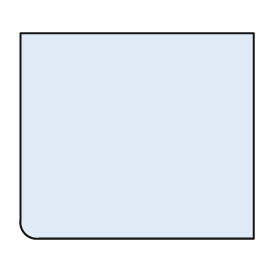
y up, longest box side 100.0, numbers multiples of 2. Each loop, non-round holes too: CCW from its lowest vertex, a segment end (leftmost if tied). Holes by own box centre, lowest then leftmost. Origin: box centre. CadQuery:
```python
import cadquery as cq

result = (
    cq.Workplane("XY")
    .moveTo(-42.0, -44.0)
    .lineTo(50.0, -44.0)
    .lineTo(50.0, 44.0)
    .lineTo(-50.0, 44.0)
    .lineTo(-50.0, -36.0)
    .threePointArc((-48.0, -42.0), (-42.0, -44.0))
    .close()
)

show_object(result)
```